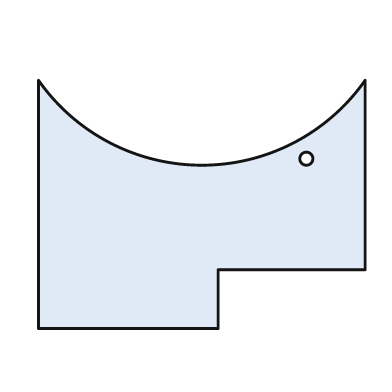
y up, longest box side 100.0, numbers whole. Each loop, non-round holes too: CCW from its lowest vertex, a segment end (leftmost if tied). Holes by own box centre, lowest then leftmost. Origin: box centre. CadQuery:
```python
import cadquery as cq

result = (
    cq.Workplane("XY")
    .moveTo(-50.0, -38.0)
    .lineTo(5.0, -38.0)
    .lineTo(5.0, -20.0)
    .lineTo(50.0, -20.0)
    .lineTo(50.0, 38.0)
    .threePointArc((0.0, 12.0), (-50.0, 38.0))
    .close()
    .moveTo(32.0, 14.0)
    .circle(2.0)
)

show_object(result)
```